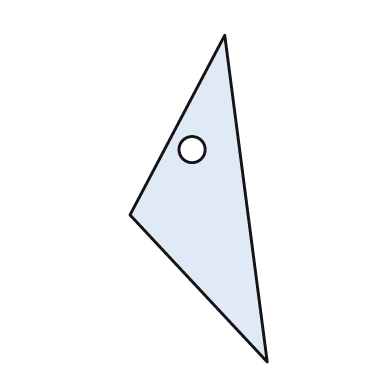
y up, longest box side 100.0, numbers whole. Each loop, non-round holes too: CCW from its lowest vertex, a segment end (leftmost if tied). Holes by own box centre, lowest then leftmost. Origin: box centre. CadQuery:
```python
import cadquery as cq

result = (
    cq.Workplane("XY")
    .moveTo(21.0, -50.0)
    .lineTo(8.0, 50.0)
    .lineTo(-21.0, -5.0)
    .close()
    .moveTo(-2.0, 15.0)
    .circle(4.0)
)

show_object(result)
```